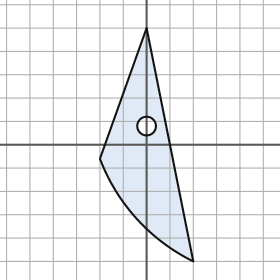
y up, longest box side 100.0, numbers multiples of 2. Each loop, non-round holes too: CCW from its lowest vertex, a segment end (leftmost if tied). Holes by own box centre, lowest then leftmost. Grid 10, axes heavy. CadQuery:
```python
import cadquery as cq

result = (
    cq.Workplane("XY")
    .moveTo(20.0, -50.0)
    .lineTo(0.0, 50.0)
    .lineTo(-20.0, -6.0)
    .threePointArc((-4.0, -32.0), (20.0, -50.0))
    .close()
    .moveTo(0.0, 8.0)
    .circle(4.0)
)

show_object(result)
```